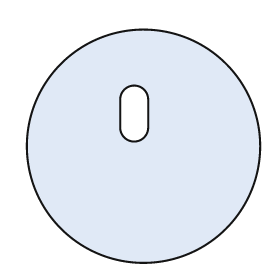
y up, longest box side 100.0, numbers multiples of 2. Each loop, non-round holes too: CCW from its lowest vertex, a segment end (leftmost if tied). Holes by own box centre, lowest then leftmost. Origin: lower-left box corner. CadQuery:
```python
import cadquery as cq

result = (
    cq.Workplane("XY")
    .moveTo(50.0, 50.0)
    .circle(50.0)
    .moveTo(40.0, 58.0)
    .threePointArc((46.0, 52.0), (52.0, 58.0))
    .lineTo(52.0, 70.0)
    .threePointArc((46.0, 76.0), (40.0, 70.0))
    .close()
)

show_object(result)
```